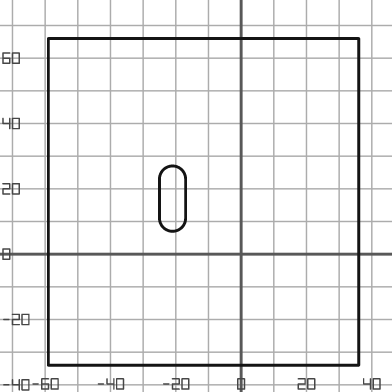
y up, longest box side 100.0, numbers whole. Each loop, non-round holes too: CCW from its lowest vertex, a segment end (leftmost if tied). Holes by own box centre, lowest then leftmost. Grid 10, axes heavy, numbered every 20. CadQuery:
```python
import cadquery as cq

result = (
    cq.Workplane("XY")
    .moveTo(-59.0, -34.0)
    .lineTo(36.0, -34.0)
    .lineTo(36.0, 66.0)
    .lineTo(-59.0, 66.0)
    .close()
    .moveTo(-25.0, 11.0)
    .threePointArc((-21.0, 7.0), (-17.0, 11.0))
    .lineTo(-17.0, 23.0)
    .threePointArc((-21.0, 27.0), (-25.0, 23.0))
    .close()
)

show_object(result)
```